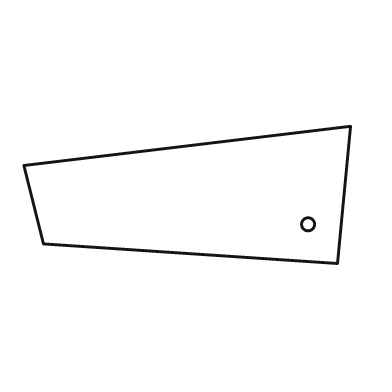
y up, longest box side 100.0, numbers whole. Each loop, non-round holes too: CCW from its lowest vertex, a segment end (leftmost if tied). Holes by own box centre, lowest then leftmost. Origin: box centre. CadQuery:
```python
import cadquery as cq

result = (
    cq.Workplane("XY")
    .moveTo(46.0, -21.0)
    .lineTo(50.0, 21.0)
    .lineTo(-50.0, 9.0)
    .lineTo(-44.0, -15.0)
    .close()
    .moveTo(37.0, -9.0)
    .circle(2.0)
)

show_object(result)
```